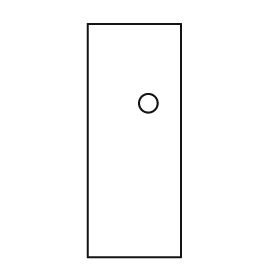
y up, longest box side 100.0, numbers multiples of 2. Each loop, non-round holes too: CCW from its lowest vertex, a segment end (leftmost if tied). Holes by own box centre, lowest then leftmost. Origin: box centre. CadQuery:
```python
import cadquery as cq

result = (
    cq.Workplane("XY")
    .moveTo(-20.0, -50.0)
    .lineTo(20.0, -50.0)
    .lineTo(20.0, 50.0)
    .lineTo(-20.0, 50.0)
    .close()
    .moveTo(6.0, 16.0)
    .circle(4.0)
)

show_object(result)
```